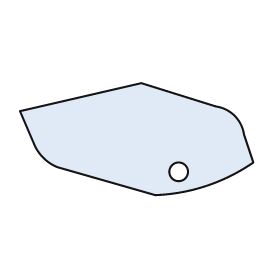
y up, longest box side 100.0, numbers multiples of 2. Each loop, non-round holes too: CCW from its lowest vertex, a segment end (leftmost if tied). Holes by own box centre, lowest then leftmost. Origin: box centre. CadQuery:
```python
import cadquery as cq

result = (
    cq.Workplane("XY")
    .moveTo(8.0, -24.0)
    .threePointArc((30.0, -20.0), (50.0, -10.0))
    .lineTo(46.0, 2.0)
    .threePointArc((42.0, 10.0), (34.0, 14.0))
    .lineTo(2.0, 24.0)
    .lineTo(-50.0, 12.0)
    .lineTo(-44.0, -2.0)
    .threePointArc((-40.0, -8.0), (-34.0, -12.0))
    .close()
    .moveTo(18.0, -14.0)
    .circle(4.0)
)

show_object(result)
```